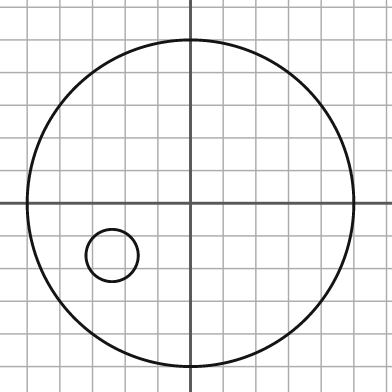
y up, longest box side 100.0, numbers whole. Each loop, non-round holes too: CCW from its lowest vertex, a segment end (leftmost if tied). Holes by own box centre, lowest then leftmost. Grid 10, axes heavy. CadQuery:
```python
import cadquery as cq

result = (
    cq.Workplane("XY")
    .moveTo(0.0, 0.0)
    .circle(50.0)
    .moveTo(-24.0, -16.0)
    .circle(8.0)
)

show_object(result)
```